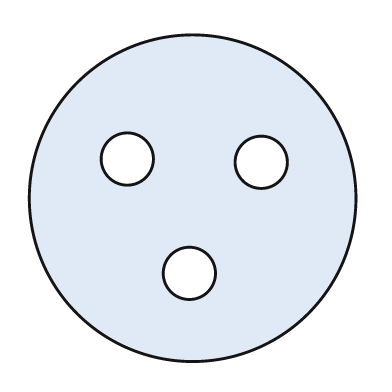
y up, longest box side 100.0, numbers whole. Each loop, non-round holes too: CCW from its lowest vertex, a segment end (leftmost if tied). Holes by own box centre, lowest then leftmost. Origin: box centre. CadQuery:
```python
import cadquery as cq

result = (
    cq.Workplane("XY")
    .moveTo(0.0, 0.0)
    .circle(50.0)
    .moveTo(-1.0, -23.0)
    .circle(8.0)
    .moveTo(21.0, 11.0)
    .circle(8.0)
    .moveTo(-20.0, 12.0)
    .circle(8.0)
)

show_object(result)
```